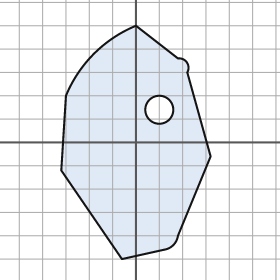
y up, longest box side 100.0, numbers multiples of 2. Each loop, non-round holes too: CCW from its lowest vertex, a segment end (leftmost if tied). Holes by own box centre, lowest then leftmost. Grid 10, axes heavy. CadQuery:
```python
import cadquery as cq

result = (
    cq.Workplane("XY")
    .moveTo(-6.0, -50.0)
    .lineTo(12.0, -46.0)
    .threePointArc((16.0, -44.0), (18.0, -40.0))
    .lineTo(32.0, -6.0)
    .lineTo(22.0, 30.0)
    .threePointArc((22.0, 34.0), (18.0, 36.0))
    .lineTo(0.0, 50.0)
    .threePointArc((-18.0, 38.0), (-30.0, 20.0))
    .lineTo(-32.0, -12.0)
    .close()
    .moveTo(10.0, 14.0)
    .circle(6.0)
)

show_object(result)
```